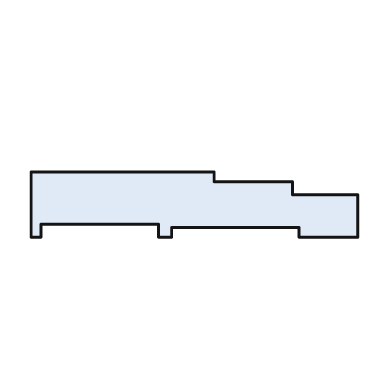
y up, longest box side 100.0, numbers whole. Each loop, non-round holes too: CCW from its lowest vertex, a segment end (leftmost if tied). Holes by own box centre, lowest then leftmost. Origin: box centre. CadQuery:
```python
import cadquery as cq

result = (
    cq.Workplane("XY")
    .moveTo(-50.0, -10.0)
    .lineTo(-47.0, -10.0)
    .lineTo(-47.0, -6.0)
    .lineTo(-11.0, -6.0)
    .lineTo(-11.0, -10.0)
    .lineTo(-7.0, -10.0)
    .lineTo(-7.0, -7.0)
    .lineTo(32.0, -7.0)
    .lineTo(32.0, -10.0)
    .lineTo(50.0, -10.0)
    .lineTo(50.0, 3.0)
    .lineTo(30.0, 3.0)
    .lineTo(30.0, 7.0)
    .lineTo(6.0, 7.0)
    .lineTo(6.0, 10.0)
    .lineTo(-50.0, 10.0)
    .close()
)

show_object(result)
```